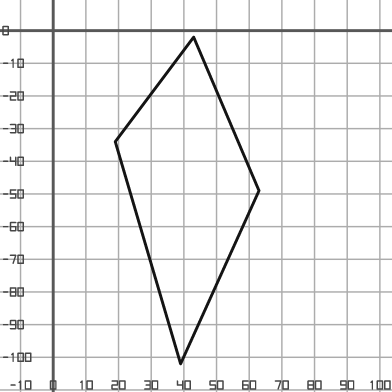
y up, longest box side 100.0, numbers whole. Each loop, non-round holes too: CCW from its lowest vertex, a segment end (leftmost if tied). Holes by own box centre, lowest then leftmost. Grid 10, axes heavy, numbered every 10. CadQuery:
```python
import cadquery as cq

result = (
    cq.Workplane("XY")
    .moveTo(39.0, -102.0)
    .lineTo(63.0, -49.0)
    .lineTo(43.0, -2.0)
    .lineTo(19.0, -34.0)
    .close()
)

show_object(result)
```